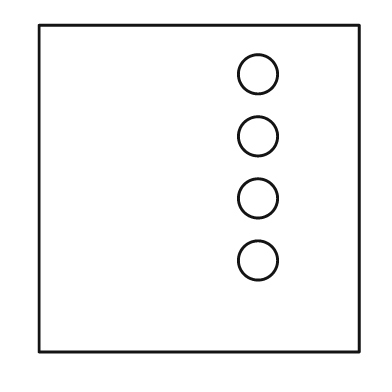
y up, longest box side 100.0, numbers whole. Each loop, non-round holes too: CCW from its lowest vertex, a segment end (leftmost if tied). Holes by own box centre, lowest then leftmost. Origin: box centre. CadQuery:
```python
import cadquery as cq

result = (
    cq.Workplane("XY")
    .moveTo(-49.0, -50.0)
    .lineTo(49.0, -50.0)
    .lineTo(49.0, 50.0)
    .lineTo(-49.0, 50.0)
    .close()
    .moveTo(18.0, -22.0)
    .circle(6.0)
    .moveTo(18.0, -3.0)
    .circle(6.0)
    .moveTo(18.0, 16.0)
    .circle(6.0)
    .moveTo(18.0, 35.0)
    .circle(6.0)
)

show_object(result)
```